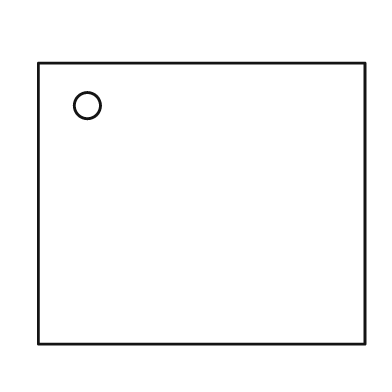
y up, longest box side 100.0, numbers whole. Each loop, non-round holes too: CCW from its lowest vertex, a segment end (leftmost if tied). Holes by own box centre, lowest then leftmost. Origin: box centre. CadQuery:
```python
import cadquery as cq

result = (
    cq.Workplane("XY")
    .moveTo(-50.0, -43.0)
    .lineTo(50.0, -43.0)
    .lineTo(50.0, 43.0)
    .lineTo(-50.0, 43.0)
    .close()
    .moveTo(-35.0, 30.0)
    .circle(4.0)
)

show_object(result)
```